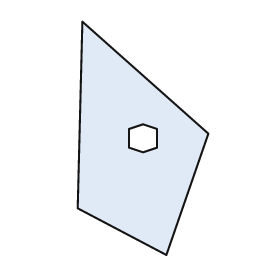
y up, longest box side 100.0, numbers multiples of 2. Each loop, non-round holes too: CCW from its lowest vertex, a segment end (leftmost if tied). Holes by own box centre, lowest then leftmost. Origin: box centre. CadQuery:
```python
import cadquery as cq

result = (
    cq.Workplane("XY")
    .moveTo(10.0, -50.0)
    .lineTo(28.0, 2.0)
    .lineTo(-26.0, 50.0)
    .lineTo(-28.0, -30.0)
    .close()
    .moveTo(0.0, -6.0)
    .lineTo(6.0, -4.0)
    .lineTo(6.0, 4.0)
    .lineTo(0.0, 6.0)
    .lineTo(-6.0, 4.0)
    .lineTo(-6.0, -4.0)
    .close()
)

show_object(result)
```